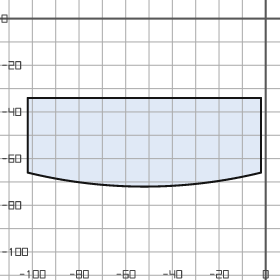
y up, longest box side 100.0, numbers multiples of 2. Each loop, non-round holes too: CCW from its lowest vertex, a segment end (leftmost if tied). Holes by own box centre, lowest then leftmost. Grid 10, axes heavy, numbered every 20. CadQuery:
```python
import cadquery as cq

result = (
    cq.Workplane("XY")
    .moveTo(-102.0, -66.0)
    .threePointArc((-52.0, -72.0), (-2.0, -66.0))
    .lineTo(-2.0, -34.0)
    .lineTo(-102.0, -34.0)
    .close()
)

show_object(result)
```